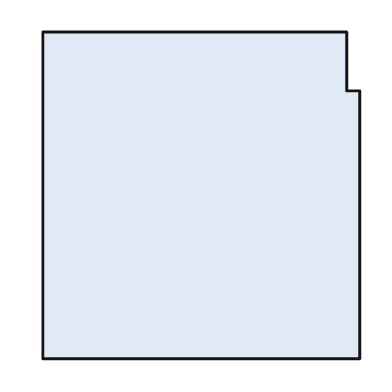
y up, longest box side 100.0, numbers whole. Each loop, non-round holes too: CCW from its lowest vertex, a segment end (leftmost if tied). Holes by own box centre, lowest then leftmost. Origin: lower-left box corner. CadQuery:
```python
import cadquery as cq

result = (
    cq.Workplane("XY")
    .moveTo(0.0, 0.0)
    .lineTo(97.0, 0.0)
    .lineTo(97.0, 82.0)
    .lineTo(93.0, 82.0)
    .lineTo(93.0, 100.0)
    .lineTo(0.0, 100.0)
    .close()
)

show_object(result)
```